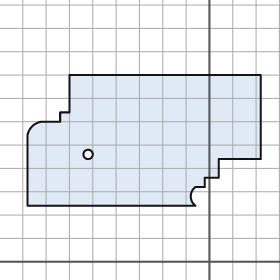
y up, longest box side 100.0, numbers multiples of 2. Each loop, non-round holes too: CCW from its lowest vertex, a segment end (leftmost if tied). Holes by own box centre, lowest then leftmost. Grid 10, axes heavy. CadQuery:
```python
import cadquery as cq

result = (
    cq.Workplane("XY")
    .moveTo(-78.0, 24.0)
    .lineTo(-6.0, 24.0)
    .threePointArc((-8.0, 28.0), (-6.0, 32.0))
    .lineTo(-2.0, 32.0)
    .lineTo(-2.0, 36.0)
    .lineTo(4.0, 36.0)
    .lineTo(4.0, 44.0)
    .lineTo(22.0, 44.0)
    .lineTo(22.0, 80.0)
    .lineTo(-60.0, 80.0)
    .lineTo(-60.0, 64.0)
    .lineTo(-64.0, 64.0)
    .lineTo(-64.0, 60.0)
    .lineTo(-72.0, 60.0)
    .threePointArc((-76.0, 58.0), (-78.0, 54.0))
    .close()
    .moveTo(-52.0, 46.0)
    .circle(2.0)
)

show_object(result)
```